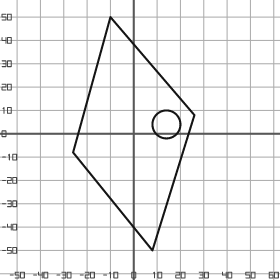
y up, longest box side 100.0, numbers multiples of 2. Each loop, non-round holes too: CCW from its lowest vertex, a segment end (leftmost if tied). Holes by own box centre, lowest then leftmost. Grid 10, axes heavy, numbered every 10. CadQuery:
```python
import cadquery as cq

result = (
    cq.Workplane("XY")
    .moveTo(8.0, -50.0)
    .lineTo(26.0, 8.0)
    .lineTo(-10.0, 50.0)
    .lineTo(-26.0, -8.0)
    .close()
    .moveTo(14.0, 4.0)
    .circle(6.0)
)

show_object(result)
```